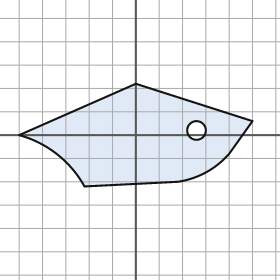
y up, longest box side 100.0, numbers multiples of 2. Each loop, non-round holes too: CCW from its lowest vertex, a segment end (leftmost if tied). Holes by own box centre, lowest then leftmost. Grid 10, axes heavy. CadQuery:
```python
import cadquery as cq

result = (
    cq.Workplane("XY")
    .moveTo(-22.0, -22.0)
    .lineTo(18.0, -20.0)
    .threePointArc((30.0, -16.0), (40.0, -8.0))
    .lineTo(50.0, 6.0)
    .lineTo(0.0, 22.0)
    .lineTo(-50.0, 0.0)
    .threePointArc((-34.0, -8.0), (-22.0, -22.0))
    .close()
    .moveTo(26.0, 2.0)
    .circle(4.0)
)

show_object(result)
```